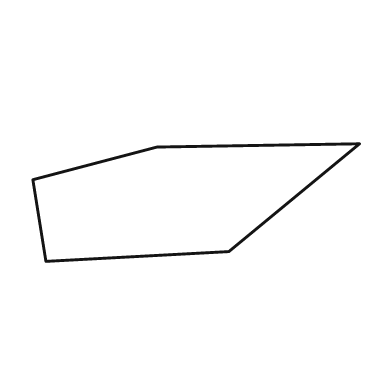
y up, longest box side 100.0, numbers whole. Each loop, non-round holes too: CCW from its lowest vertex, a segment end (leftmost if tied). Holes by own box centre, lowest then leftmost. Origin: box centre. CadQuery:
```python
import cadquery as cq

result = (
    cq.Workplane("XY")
    .moveTo(-46.0, -18.0)
    .lineTo(10.0, -15.0)
    .lineTo(50.0, 18.0)
    .lineTo(-12.0, 17.0)
    .lineTo(-50.0, 7.0)
    .close()
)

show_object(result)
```